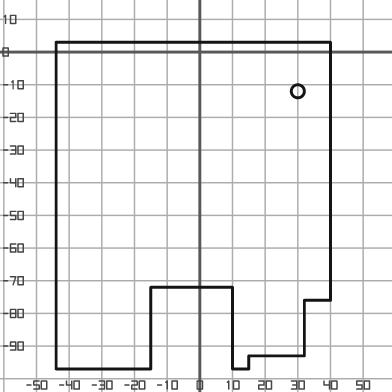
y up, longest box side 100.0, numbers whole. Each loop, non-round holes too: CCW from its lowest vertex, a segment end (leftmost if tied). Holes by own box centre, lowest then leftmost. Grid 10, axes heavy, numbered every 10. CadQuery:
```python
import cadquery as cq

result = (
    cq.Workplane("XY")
    .moveTo(-44.0, -97.0)
    .lineTo(-15.0, -97.0)
    .lineTo(-15.0, -72.0)
    .lineTo(10.0, -72.0)
    .lineTo(10.0, -97.0)
    .lineTo(15.0, -97.0)
    .lineTo(15.0, -93.0)
    .lineTo(32.0, -93.0)
    .lineTo(32.0, -76.0)
    .lineTo(40.0, -76.0)
    .lineTo(40.0, 3.0)
    .lineTo(-44.0, 3.0)
    .close()
    .moveTo(30.0, -12.0)
    .circle(2.0)
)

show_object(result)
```